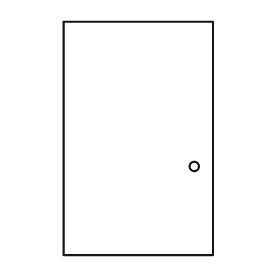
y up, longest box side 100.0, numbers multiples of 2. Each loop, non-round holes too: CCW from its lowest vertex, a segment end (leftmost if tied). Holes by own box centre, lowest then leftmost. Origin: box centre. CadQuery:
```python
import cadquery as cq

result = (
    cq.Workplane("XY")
    .moveTo(-32.0, -50.0)
    .lineTo(32.0, -50.0)
    .lineTo(32.0, 50.0)
    .lineTo(-32.0, 50.0)
    .close()
    .moveTo(24.0, -12.0)
    .circle(2.0)
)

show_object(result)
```